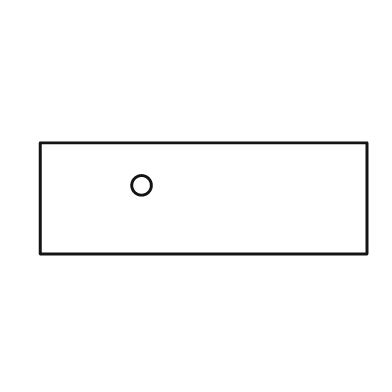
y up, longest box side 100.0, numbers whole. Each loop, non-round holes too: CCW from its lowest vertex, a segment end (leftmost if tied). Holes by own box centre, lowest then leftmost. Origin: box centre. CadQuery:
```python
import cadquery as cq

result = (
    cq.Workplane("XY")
    .moveTo(-50.0, -17.0)
    .lineTo(50.0, -17.0)
    .lineTo(50.0, 17.0)
    .lineTo(-50.0, 17.0)
    .close()
    .moveTo(-19.0, 4.0)
    .circle(3.0)
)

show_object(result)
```